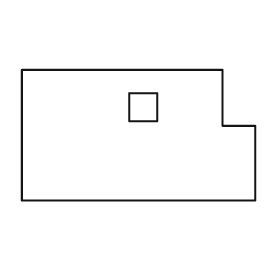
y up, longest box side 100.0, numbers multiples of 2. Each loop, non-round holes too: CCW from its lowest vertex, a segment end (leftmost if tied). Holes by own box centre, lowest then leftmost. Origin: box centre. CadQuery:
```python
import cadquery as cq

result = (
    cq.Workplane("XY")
    .moveTo(-50.0, -28.0)
    .lineTo(50.0, -28.0)
    .lineTo(50.0, 4.0)
    .lineTo(36.0, 4.0)
    .lineTo(36.0, 28.0)
    .lineTo(-50.0, 28.0)
    .close()
    .moveTo(-4.0, 6.0)
    .lineTo(8.0, 6.0)
    .lineTo(8.0, 18.0)
    .lineTo(-4.0, 18.0)
    .close()
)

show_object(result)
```